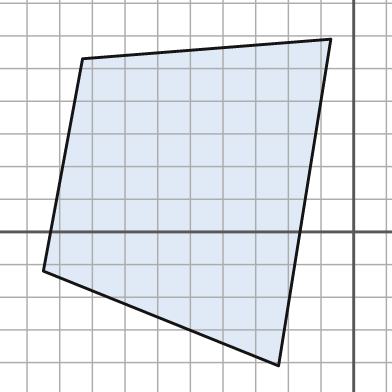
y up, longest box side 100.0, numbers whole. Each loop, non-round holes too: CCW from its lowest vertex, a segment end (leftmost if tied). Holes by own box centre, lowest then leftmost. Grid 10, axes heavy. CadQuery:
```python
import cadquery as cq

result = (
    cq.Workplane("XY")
    .moveTo(-23.0, -41.0)
    .lineTo(-7.0, 59.0)
    .lineTo(-83.0, 53.0)
    .lineTo(-95.0, -12.0)
    .close()
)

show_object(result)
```